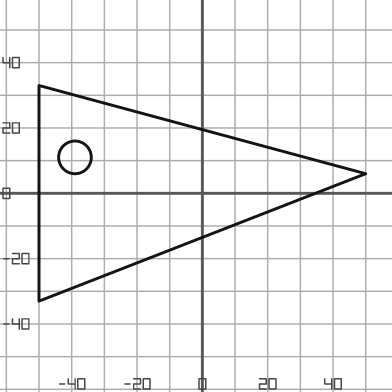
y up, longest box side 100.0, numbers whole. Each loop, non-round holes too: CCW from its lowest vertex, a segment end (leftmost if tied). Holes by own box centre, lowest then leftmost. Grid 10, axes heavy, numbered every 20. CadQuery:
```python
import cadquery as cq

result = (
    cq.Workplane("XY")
    .moveTo(-50.0, -33.0)
    .lineTo(50.0, 6.0)
    .lineTo(-50.0, 33.0)
    .close()
    .moveTo(-39.0, 11.0)
    .circle(5.0)
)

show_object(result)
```